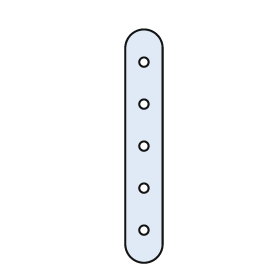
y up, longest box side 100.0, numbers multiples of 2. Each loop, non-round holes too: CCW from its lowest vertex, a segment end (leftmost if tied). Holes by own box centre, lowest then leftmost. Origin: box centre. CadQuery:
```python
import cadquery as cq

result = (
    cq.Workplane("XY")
    .moveTo(-8.0, -42.0)
    .threePointArc((0.0, -50.0), (8.0, -42.0))
    .lineTo(8.0, 42.0)
    .threePointArc((0.0, 50.0), (-8.0, 42.0))
    .close()
    .moveTo(0.0, -36.0)
    .circle(2.0)
    .moveTo(0.0, -18.0)
    .circle(2.0)
    .moveTo(0.0, 0.0)
    .circle(2.0)
    .moveTo(0.0, 18.0)
    .circle(2.0)
    .moveTo(0.0, 36.0)
    .circle(2.0)
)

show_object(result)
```